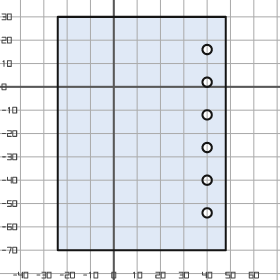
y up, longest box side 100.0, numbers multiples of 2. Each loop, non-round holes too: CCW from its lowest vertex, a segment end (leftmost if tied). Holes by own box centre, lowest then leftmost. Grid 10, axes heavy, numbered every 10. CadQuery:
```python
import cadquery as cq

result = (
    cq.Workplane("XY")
    .moveTo(-24.0, -70.0)
    .lineTo(48.0, -70.0)
    .lineTo(48.0, 30.0)
    .lineTo(-24.0, 30.0)
    .close()
    .moveTo(40.0, -54.0)
    .circle(2.0)
    .moveTo(40.0, -40.0)
    .circle(2.0)
    .moveTo(40.0, -26.0)
    .circle(2.0)
    .moveTo(40.0, -12.0)
    .circle(2.0)
    .moveTo(40.0, 2.0)
    .circle(2.0)
    .moveTo(40.0, 16.0)
    .circle(2.0)
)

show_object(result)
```